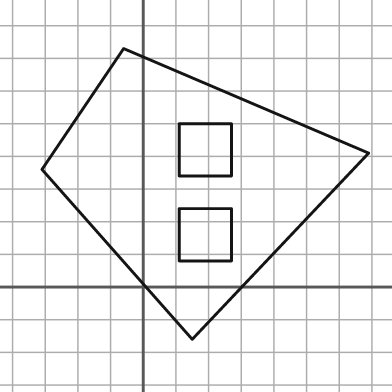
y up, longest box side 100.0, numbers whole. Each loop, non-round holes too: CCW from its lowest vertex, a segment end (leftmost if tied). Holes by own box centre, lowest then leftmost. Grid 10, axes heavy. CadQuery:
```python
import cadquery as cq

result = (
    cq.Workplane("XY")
    .moveTo(15.0, -16.0)
    .lineTo(69.0, 41.0)
    .lineTo(-6.0, 73.0)
    .lineTo(-31.0, 36.0)
    .close()
    .moveTo(11.0, 8.0)
    .lineTo(27.0, 8.0)
    .lineTo(27.0, 24.0)
    .lineTo(11.0, 24.0)
    .close()
    .moveTo(11.0, 34.0)
    .lineTo(27.0, 34.0)
    .lineTo(27.0, 50.0)
    .lineTo(11.0, 50.0)
    .close()
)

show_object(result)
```